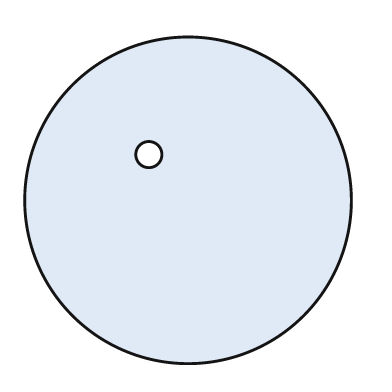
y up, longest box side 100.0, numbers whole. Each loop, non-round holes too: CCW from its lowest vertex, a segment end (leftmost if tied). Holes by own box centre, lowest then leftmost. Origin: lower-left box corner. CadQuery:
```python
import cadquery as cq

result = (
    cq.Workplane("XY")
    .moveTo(50.0, 50.0)
    .circle(50.0)
    .moveTo(38.0, 64.0)
    .circle(4.0)
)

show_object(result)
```